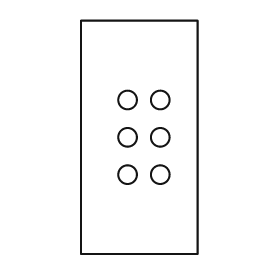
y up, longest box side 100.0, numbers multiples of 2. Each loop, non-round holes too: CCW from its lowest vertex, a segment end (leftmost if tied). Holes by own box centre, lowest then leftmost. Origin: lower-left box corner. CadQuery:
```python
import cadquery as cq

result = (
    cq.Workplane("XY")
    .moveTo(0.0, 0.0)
    .lineTo(50.0, 0.0)
    .lineTo(50.0, 100.0)
    .lineTo(0.0, 100.0)
    .close()
    .moveTo(20.0, 34.0)
    .circle(4.0)
    .moveTo(34.0, 34.0)
    .circle(4.0)
    .moveTo(20.0, 50.0)
    .circle(4.0)
    .moveTo(34.0, 50.0)
    .circle(4.0)
    .moveTo(20.0, 66.0)
    .circle(4.0)
    .moveTo(34.0, 66.0)
    .circle(4.0)
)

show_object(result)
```